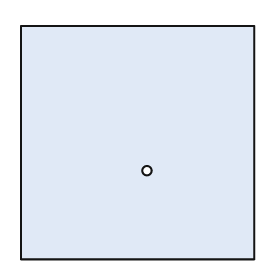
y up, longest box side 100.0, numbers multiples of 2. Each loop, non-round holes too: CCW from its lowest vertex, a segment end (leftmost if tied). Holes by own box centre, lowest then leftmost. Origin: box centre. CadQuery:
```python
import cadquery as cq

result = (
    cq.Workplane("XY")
    .moveTo(-50.0, -50.0)
    .lineTo(50.0, -50.0)
    .lineTo(50.0, 50.0)
    .lineTo(-50.0, 50.0)
    .close()
    .moveTo(4.0, -12.0)
    .circle(2.0)
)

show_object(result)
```